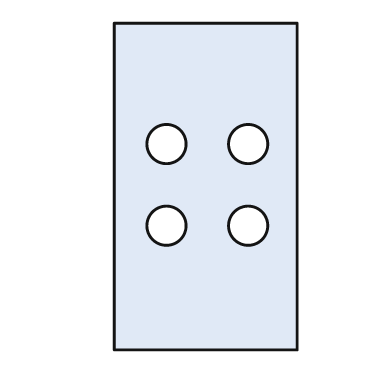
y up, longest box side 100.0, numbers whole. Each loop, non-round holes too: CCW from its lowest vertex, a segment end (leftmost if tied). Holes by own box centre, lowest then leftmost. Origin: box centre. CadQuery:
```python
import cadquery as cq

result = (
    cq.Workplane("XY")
    .moveTo(-28.0, -50.0)
    .lineTo(28.0, -50.0)
    .lineTo(28.0, 50.0)
    .lineTo(-28.0, 50.0)
    .close()
    .moveTo(-12.0, -12.0)
    .circle(6.0)
    .moveTo(13.0, -12.0)
    .circle(6.0)
    .moveTo(-12.0, 13.0)
    .circle(6.0)
    .moveTo(13.0, 13.0)
    .circle(6.0)
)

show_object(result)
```